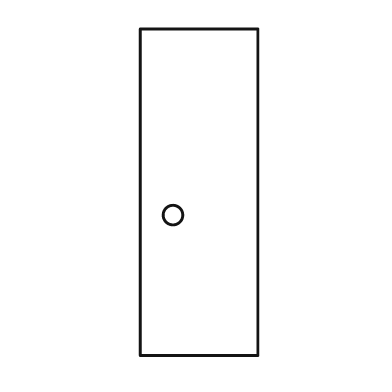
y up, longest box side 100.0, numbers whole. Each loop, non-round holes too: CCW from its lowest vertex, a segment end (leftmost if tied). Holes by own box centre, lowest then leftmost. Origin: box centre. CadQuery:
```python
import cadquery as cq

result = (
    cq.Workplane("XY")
    .moveTo(-18.0, -50.0)
    .lineTo(18.0, -50.0)
    .lineTo(18.0, 50.0)
    .lineTo(-18.0, 50.0)
    .close()
    .moveTo(-8.0, -7.0)
    .circle(3.0)
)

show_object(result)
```